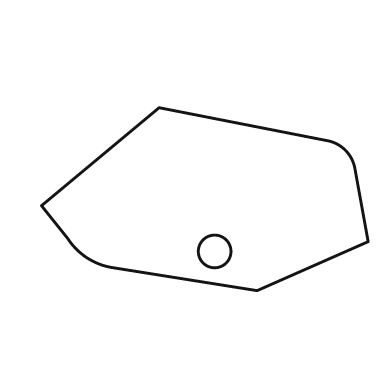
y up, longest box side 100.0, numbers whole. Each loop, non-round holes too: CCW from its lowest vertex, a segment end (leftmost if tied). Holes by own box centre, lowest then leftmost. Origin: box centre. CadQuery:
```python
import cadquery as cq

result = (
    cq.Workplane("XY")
    .moveTo(16.0, -28.0)
    .lineTo(50.0, -13.0)
    .lineTo(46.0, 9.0)
    .threePointArc((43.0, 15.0), (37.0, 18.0))
    .lineTo(-14.0, 28.0)
    .lineTo(-50.0, -2.0)
    .lineTo(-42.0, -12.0)
    .threePointArc((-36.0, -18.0), (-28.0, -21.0))
    .close()
    .moveTo(3.0, -16.0)
    .circle(5.0)
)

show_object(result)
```